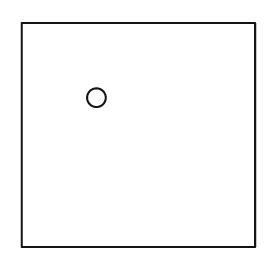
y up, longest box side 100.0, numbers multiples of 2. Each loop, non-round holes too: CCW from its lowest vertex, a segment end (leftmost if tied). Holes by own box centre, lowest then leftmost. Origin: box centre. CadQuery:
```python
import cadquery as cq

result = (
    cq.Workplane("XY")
    .moveTo(-50.0, -48.0)
    .lineTo(50.0, -48.0)
    .lineTo(50.0, 48.0)
    .lineTo(-50.0, 48.0)
    .close()
    .moveTo(-18.0, 16.0)
    .circle(4.0)
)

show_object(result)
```